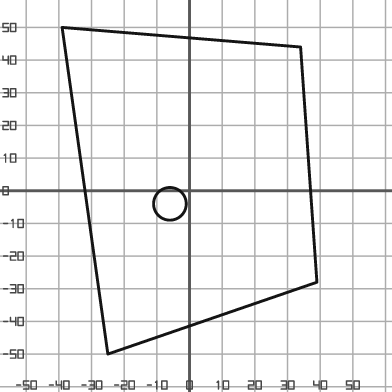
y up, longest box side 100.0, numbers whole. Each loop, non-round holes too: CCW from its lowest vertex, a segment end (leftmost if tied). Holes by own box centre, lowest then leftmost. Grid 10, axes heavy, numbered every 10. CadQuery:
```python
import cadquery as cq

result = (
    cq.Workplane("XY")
    .moveTo(-25.0, -50.0)
    .lineTo(39.0, -28.0)
    .lineTo(34.0, 44.0)
    .lineTo(-39.0, 50.0)
    .close()
    .moveTo(-6.0, -4.0)
    .circle(5.0)
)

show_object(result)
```